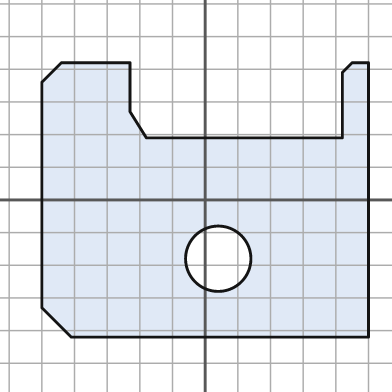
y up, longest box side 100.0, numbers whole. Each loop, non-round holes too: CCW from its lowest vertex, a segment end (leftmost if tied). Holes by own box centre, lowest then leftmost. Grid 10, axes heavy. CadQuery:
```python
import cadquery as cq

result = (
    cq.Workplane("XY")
    .moveTo(-41.0, -42.0)
    .lineTo(50.0, -42.0)
    .lineTo(50.0, 42.0)
    .lineTo(45.0, 42.0)
    .lineTo(42.0, 39.0)
    .lineTo(42.0, 19.0)
    .lineTo(-18.0, 19.0)
    .lineTo(-23.0, 27.0)
    .lineTo(-23.0, 42.0)
    .lineTo(-44.0, 42.0)
    .lineTo(-50.0, 36.0)
    .lineTo(-50.0, -33.0)
    .close()
    .moveTo(4.0, -18.0)
    .circle(10.0)
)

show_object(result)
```